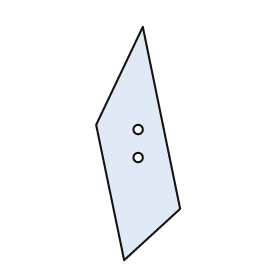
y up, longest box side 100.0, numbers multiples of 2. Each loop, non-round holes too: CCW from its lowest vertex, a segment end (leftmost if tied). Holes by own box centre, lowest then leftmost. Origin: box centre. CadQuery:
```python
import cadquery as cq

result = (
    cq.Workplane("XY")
    .moveTo(-6.0, -50.0)
    .lineTo(18.0, -28.0)
    .lineTo(2.0, 50.0)
    .lineTo(-18.0, 8.0)
    .close()
    .moveTo(0.0, -6.0)
    .circle(2.0)
    .moveTo(0.0, 6.0)
    .circle(2.0)
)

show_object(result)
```